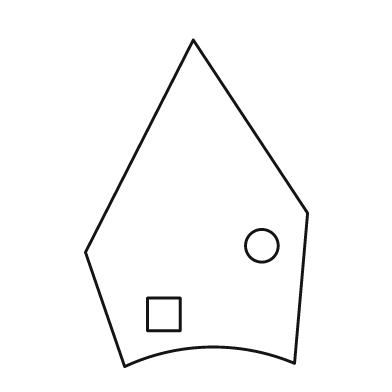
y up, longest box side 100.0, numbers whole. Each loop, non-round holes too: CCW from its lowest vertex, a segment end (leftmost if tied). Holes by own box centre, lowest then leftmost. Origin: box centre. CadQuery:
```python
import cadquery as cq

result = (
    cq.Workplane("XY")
    .moveTo(-22.0, -50.0)
    .threePointArc((4.0, -44.0), (30.0, -49.0))
    .lineTo(34.0, -3.0)
    .lineTo(-1.0, 50.0)
    .lineTo(-34.0, -15.0)
    .close()
    .moveTo(-15.0, -39.0)
    .lineTo(-5.0, -39.0)
    .lineTo(-5.0, -29.0)
    .lineTo(-15.0, -29.0)
    .close()
    .moveTo(20.0, -13.0)
    .circle(5.0)
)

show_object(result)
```